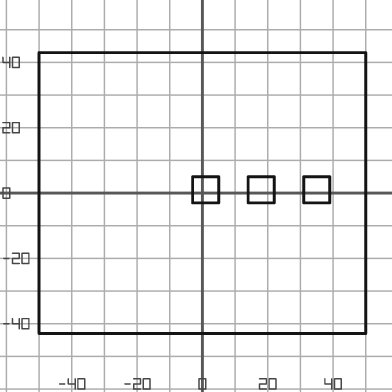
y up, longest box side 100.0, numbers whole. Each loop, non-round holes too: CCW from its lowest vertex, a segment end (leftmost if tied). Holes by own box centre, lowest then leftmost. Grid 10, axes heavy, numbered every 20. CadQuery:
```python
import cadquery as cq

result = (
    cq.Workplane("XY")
    .moveTo(-50.0, -43.0)
    .lineTo(50.0, -43.0)
    .lineTo(50.0, 43.0)
    .lineTo(-50.0, 43.0)
    .close()
    .moveTo(-3.0, -3.0)
    .lineTo(5.0, -3.0)
    .lineTo(5.0, 5.0)
    .lineTo(-3.0, 5.0)
    .close()
    .moveTo(14.0, -3.0)
    .lineTo(22.0, -3.0)
    .lineTo(22.0, 5.0)
    .lineTo(14.0, 5.0)
    .close()
    .moveTo(31.0, -3.0)
    .lineTo(39.0, -3.0)
    .lineTo(39.0, 5.0)
    .lineTo(31.0, 5.0)
    .close()
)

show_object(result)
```